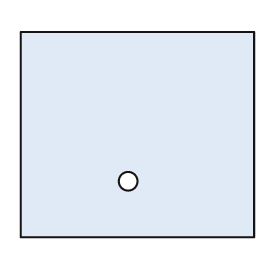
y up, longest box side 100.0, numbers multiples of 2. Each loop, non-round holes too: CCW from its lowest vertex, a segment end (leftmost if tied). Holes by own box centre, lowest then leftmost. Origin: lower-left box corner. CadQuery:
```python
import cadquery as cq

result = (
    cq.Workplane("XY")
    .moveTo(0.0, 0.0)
    .lineTo(100.0, 0.0)
    .lineTo(100.0, 88.0)
    .lineTo(0.0, 88.0)
    .close()
    .moveTo(46.0, 24.0)
    .circle(4.0)
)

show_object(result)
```